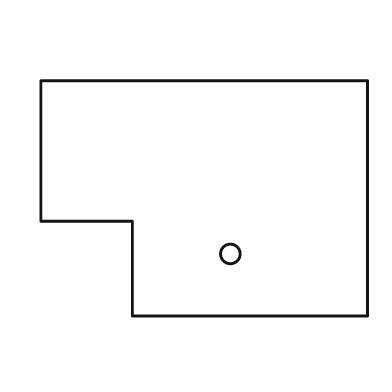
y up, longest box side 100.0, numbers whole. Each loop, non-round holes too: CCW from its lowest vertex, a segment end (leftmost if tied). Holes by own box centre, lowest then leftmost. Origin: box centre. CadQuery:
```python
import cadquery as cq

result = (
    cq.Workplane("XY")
    .moveTo(-22.0, -36.0)
    .lineTo(50.0, -36.0)
    .lineTo(50.0, 36.0)
    .lineTo(-50.0, 36.0)
    .lineTo(-50.0, -7.0)
    .lineTo(-22.0, -7.0)
    .close()
    .moveTo(8.0, -17.0)
    .circle(3.0)
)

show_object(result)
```